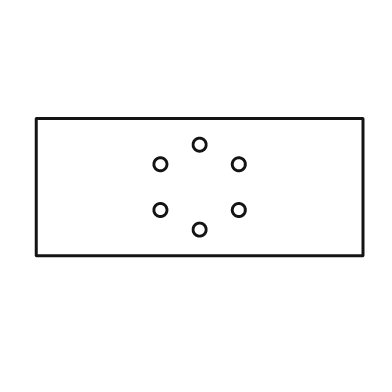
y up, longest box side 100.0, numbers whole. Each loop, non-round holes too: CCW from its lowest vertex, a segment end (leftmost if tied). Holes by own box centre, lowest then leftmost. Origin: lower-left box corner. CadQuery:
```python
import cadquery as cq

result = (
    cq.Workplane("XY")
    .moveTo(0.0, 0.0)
    .lineTo(100.0, 0.0)
    .lineTo(100.0, 42.0)
    .lineTo(0.0, 42.0)
    .close()
    .moveTo(50.0, 8.0)
    .circle(2.0)
    .moveTo(38.0, 14.0)
    .circle(2.0)
    .moveTo(62.0, 14.0)
    .circle(2.0)
    .moveTo(38.0, 28.0)
    .circle(2.0)
    .moveTo(62.0, 28.0)
    .circle(2.0)
    .moveTo(50.0, 34.0)
    .circle(2.0)
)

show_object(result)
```